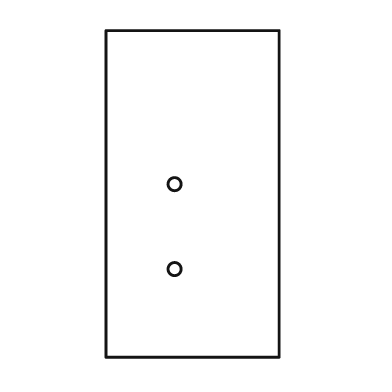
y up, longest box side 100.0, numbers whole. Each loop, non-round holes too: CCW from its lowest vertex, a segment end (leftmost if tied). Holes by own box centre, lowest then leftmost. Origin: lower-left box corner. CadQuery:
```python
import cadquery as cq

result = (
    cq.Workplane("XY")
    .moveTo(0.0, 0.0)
    .lineTo(53.0, 0.0)
    .lineTo(53.0, 100.0)
    .lineTo(0.0, 100.0)
    .close()
    .moveTo(21.0, 27.0)
    .circle(2.0)
    .moveTo(21.0, 53.0)
    .circle(2.0)
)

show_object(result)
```